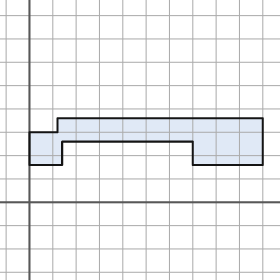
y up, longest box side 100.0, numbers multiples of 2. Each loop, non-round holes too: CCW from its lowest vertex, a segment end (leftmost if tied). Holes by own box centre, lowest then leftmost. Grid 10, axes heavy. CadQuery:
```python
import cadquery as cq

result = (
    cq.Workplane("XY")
    .moveTo(0.0, 16.0)
    .lineTo(14.0, 16.0)
    .lineTo(14.0, 26.0)
    .lineTo(70.0, 26.0)
    .lineTo(70.0, 16.0)
    .lineTo(100.0, 16.0)
    .lineTo(100.0, 36.0)
    .lineTo(12.0, 36.0)
    .lineTo(12.0, 30.0)
    .lineTo(0.0, 30.0)
    .close()
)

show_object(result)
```